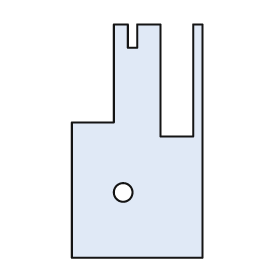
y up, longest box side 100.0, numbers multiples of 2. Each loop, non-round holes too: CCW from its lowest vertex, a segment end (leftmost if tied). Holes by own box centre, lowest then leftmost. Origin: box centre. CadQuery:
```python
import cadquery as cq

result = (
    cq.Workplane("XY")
    .moveTo(-28.0, -50.0)
    .lineTo(28.0, -50.0)
    .lineTo(28.0, 50.0)
    .lineTo(24.0, 50.0)
    .lineTo(24.0, 2.0)
    .lineTo(10.0, 2.0)
    .lineTo(10.0, 50.0)
    .lineTo(0.0, 50.0)
    .lineTo(0.0, 40.0)
    .lineTo(-4.0, 40.0)
    .lineTo(-4.0, 50.0)
    .lineTo(-10.0, 50.0)
    .lineTo(-10.0, 8.0)
    .lineTo(-28.0, 8.0)
    .close()
    .moveTo(-6.0, -22.0)
    .circle(4.0)
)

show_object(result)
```